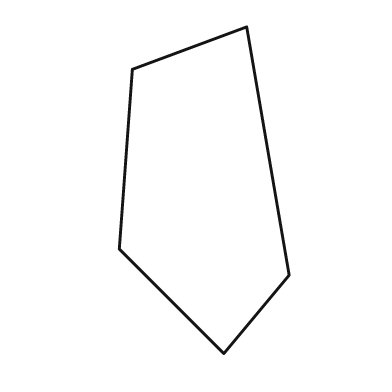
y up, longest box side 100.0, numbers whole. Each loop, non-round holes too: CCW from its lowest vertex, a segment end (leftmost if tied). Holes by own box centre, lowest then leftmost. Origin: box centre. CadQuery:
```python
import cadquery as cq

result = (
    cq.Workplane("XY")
    .moveTo(6.0, -50.0)
    .lineTo(26.0, -26.0)
    .lineTo(13.0, 50.0)
    .lineTo(-22.0, 37.0)
    .lineTo(-26.0, -18.0)
    .close()
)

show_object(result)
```